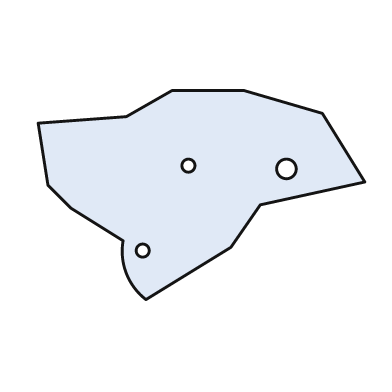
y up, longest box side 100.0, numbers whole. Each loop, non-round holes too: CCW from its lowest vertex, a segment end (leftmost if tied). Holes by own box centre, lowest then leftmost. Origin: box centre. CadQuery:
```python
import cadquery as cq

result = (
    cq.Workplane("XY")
    .moveTo(-17.0, -32.0)
    .lineTo(9.0, -16.0)
    .lineTo(18.0, -3.0)
    .lineTo(50.0, 4.0)
    .lineTo(37.0, 25.0)
    .lineTo(13.0, 32.0)
    .lineTo(-9.0, 32.0)
    .lineTo(-23.0, 24.0)
    .lineTo(-50.0, 22.0)
    .lineTo(-47.0, 3.0)
    .lineTo(-40.0, -4.0)
    .lineTo(-24.0, -14.0)
    .threePointArc((-23.0, -24.0), (-17.0, -32.0))
    .close()
    .moveTo(-18.0, -17.0)
    .circle(2.0)
    .moveTo(26.0, 8.0)
    .circle(3.0)
    .moveTo(-4.0, 9.0)
    .circle(2.0)
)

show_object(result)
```